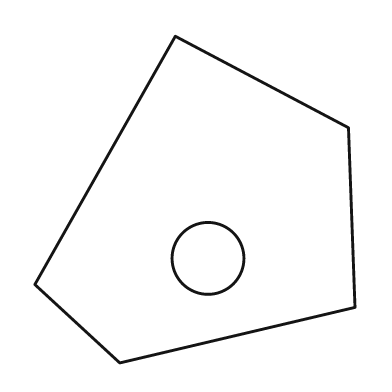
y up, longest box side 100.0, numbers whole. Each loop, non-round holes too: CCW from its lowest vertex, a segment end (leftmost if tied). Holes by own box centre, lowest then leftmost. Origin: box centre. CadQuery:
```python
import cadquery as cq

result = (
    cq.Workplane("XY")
    .moveTo(-23.0, -50.0)
    .lineTo(49.0, -33.0)
    .lineTo(47.0, 22.0)
    .lineTo(-6.0, 50.0)
    .lineTo(-49.0, -26.0)
    .close()
    .moveTo(4.0, -18.0)
    .circle(11.0)
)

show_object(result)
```